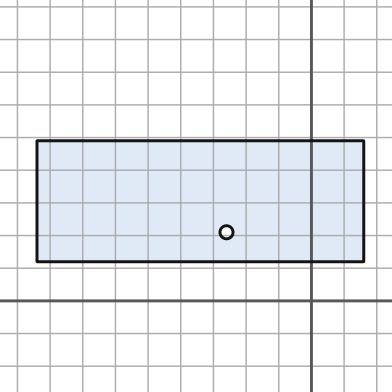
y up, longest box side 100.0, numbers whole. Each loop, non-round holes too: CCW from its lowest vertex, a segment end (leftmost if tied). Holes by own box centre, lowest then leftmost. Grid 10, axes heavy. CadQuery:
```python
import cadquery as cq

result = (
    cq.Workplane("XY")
    .moveTo(-84.0, 12.0)
    .lineTo(16.0, 12.0)
    .lineTo(16.0, 49.0)
    .lineTo(-84.0, 49.0)
    .close()
    .moveTo(-26.0, 21.0)
    .circle(2.0)
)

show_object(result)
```